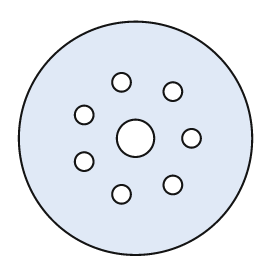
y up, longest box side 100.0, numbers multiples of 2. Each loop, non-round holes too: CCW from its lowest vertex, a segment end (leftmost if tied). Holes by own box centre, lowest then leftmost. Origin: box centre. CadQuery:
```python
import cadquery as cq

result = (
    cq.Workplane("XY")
    .moveTo(0.0, 0.0)
    .circle(50.0)
    .moveTo(-6.0, -24.0)
    .circle(4.0)
    .moveTo(16.0, -20.0)
    .circle(4.0)
    .moveTo(-22.0, -10.0)
    .circle(4.0)
    .moveTo(0.0, 0.0)
    .circle(8.0)
    .moveTo(24.0, 0.0)
    .circle(4.0)
    .moveTo(-22.0, 10.0)
    .circle(4.0)
    .moveTo(16.0, 20.0)
    .circle(4.0)
    .moveTo(-6.0, 24.0)
    .circle(4.0)
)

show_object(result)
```